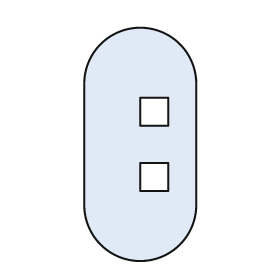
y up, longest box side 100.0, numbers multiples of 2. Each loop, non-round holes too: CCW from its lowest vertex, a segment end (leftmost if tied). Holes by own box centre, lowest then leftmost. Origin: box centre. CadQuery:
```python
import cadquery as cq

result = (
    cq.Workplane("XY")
    .moveTo(-24.0, -26.0)
    .threePointArc((0.0, -50.0), (24.0, -26.0))
    .lineTo(24.0, 26.0)
    .threePointArc((0.0, 50.0), (-24.0, 26.0))
    .close()
    .moveTo(0.0, -20.0)
    .lineTo(12.0, -20.0)
    .lineTo(12.0, -8.0)
    .lineTo(0.0, -8.0)
    .close()
    .moveTo(0.0, 8.0)
    .lineTo(12.0, 8.0)
    .lineTo(12.0, 20.0)
    .lineTo(0.0, 20.0)
    .close()
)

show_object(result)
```